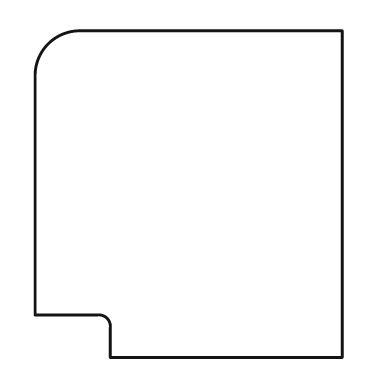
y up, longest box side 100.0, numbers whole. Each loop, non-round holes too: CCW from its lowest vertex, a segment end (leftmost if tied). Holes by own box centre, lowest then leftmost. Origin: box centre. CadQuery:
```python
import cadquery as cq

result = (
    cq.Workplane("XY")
    .moveTo(-24.0, -50.0)
    .lineTo(47.0, -50.0)
    .lineTo(47.0, 50.0)
    .lineTo(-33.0, 50.0)
    .threePointArc((-43.0, 46.0), (-47.0, 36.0))
    .lineTo(-47.0, -37.0)
    .lineTo(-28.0, -37.0)
    .threePointArc((-25.0, -38.0), (-24.0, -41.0))
    .close()
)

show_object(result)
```